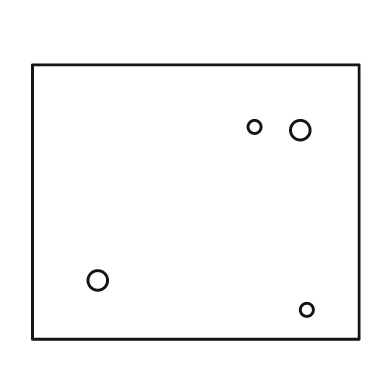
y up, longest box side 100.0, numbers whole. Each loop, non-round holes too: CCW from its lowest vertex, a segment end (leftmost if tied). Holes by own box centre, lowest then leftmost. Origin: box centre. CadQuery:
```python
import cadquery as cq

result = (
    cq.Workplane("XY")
    .moveTo(-50.0, -42.0)
    .lineTo(50.0, -42.0)
    .lineTo(50.0, 42.0)
    .lineTo(-50.0, 42.0)
    .close()
    .moveTo(34.0, -33.0)
    .circle(2.0)
    .moveTo(-30.0, -24.0)
    .circle(3.0)
    .moveTo(32.0, 22.0)
    .circle(3.0)
    .moveTo(18.0, 23.0)
    .circle(2.0)
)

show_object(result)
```